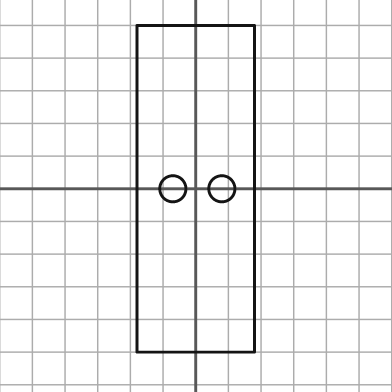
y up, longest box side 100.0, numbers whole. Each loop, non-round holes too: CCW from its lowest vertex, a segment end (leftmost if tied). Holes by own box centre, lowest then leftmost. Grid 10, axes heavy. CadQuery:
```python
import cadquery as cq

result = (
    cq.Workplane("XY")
    .moveTo(-18.0, -50.0)
    .lineTo(18.0, -50.0)
    .lineTo(18.0, 50.0)
    .lineTo(-18.0, 50.0)
    .close()
    .moveTo(-7.0, 0.0)
    .circle(4.0)
    .moveTo(8.0, 0.0)
    .circle(4.0)
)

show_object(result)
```